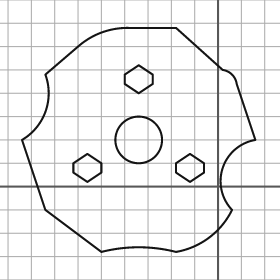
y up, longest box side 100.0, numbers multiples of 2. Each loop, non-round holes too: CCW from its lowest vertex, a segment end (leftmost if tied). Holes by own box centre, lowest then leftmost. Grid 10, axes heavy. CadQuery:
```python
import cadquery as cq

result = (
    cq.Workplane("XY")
    .moveTo(-50.0, -28.0)
    .threePointArc((-34.0, -26.0), (-18.0, -28.0))
    .threePointArc((-4.0, -22.0), (6.0, -10.0))
    .threePointArc((2.0, 8.0), (16.0, 20.0))
    .lineTo(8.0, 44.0)
    .threePointArc((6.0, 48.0), (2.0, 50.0))
    .lineTo(-18.0, 68.0)
    .lineTo(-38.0, 68.0)
    .threePointArc((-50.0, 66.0), (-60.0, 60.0))
    .lineTo(-74.0, 48.0)
    .threePointArc((-74.0, 32.0), (-84.0, 20.0))
    .lineTo(-74.0, -10.0)
    .close()
    .moveTo(-56.0, 2.0)
    .lineTo(-50.0, 6.0)
    .lineTo(-50.0, 10.0)
    .lineTo(-56.0, 14.0)
    .lineTo(-62.0, 10.0)
    .lineTo(-62.0, 6.0)
    .close()
    .moveTo(-12.0, 2.0)
    .lineTo(-6.0, 6.0)
    .lineTo(-6.0, 10.0)
    .lineTo(-12.0, 14.0)
    .lineTo(-18.0, 10.0)
    .lineTo(-18.0, 6.0)
    .close()
    .moveTo(-34.0, 20.0)
    .circle(10.0)
    .moveTo(-34.0, 40.0)
    .lineTo(-28.0, 44.0)
    .lineTo(-28.0, 48.0)
    .lineTo(-34.0, 52.0)
    .lineTo(-40.0, 48.0)
    .lineTo(-40.0, 44.0)
    .close()
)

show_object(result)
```